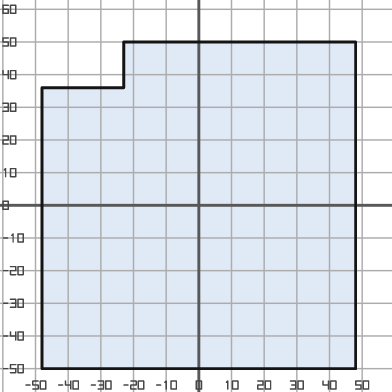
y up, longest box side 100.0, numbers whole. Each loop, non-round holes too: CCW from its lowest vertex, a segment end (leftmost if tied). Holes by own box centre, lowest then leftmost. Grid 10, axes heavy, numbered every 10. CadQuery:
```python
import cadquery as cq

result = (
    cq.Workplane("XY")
    .moveTo(-48.0, -50.0)
    .lineTo(48.0, -50.0)
    .lineTo(48.0, 50.0)
    .lineTo(-23.0, 50.0)
    .lineTo(-23.0, 36.0)
    .lineTo(-48.0, 36.0)
    .close()
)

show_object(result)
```